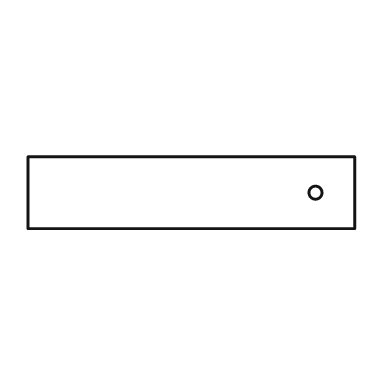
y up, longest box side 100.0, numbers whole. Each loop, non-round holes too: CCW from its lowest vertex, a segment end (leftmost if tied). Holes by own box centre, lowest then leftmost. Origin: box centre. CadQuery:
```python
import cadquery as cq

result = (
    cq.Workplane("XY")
    .moveTo(-50.0, -11.0)
    .lineTo(50.0, -11.0)
    .lineTo(50.0, 11.0)
    .lineTo(-50.0, 11.0)
    .close()
    .moveTo(38.0, 0.0)
    .circle(2.0)
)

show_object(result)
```